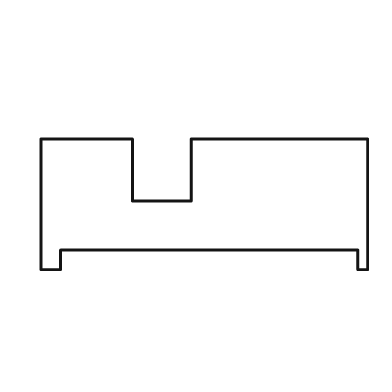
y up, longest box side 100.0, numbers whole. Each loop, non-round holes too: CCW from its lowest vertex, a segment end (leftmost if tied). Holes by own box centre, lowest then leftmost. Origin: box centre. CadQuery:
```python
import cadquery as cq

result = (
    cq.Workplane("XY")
    .moveTo(-50.0, -20.0)
    .lineTo(-44.0, -20.0)
    .lineTo(-44.0, -14.0)
    .lineTo(47.0, -14.0)
    .lineTo(47.0, -20.0)
    .lineTo(50.0, -20.0)
    .lineTo(50.0, 20.0)
    .lineTo(-4.0, 20.0)
    .lineTo(-4.0, 1.0)
    .lineTo(-22.0, 1.0)
    .lineTo(-22.0, 20.0)
    .lineTo(-50.0, 20.0)
    .close()
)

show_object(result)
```